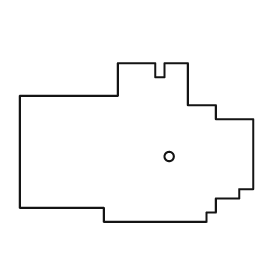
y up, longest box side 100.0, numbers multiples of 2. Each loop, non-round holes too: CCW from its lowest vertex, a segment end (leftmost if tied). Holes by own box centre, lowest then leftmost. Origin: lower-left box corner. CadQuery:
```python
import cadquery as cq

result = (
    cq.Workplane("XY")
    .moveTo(36.0, 0.0)
    .lineTo(80.0, 0.0)
    .lineTo(80.0, 4.0)
    .lineTo(84.0, 4.0)
    .lineTo(84.0, 10.0)
    .lineTo(94.0, 10.0)
    .lineTo(94.0, 14.0)
    .lineTo(100.0, 14.0)
    .lineTo(100.0, 44.0)
    .lineTo(84.0, 44.0)
    .lineTo(84.0, 50.0)
    .lineTo(72.0, 50.0)
    .lineTo(72.0, 68.0)
    .lineTo(62.0, 68.0)
    .lineTo(62.0, 62.0)
    .lineTo(58.0, 62.0)
    .lineTo(58.0, 68.0)
    .lineTo(42.0, 68.0)
    .lineTo(42.0, 54.0)
    .lineTo(0.0, 54.0)
    .lineTo(0.0, 6.0)
    .lineTo(36.0, 6.0)
    .close()
    .moveTo(64.0, 28.0)
    .circle(2.0)
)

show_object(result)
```